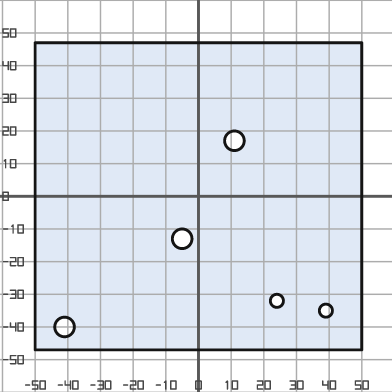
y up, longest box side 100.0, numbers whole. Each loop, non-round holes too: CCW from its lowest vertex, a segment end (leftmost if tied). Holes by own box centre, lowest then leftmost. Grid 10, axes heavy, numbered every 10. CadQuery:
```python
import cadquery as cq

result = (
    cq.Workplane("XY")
    .moveTo(-50.0, -47.0)
    .lineTo(50.0, -47.0)
    .lineTo(50.0, 47.0)
    .lineTo(-50.0, 47.0)
    .close()
    .moveTo(-41.0, -40.0)
    .circle(3.0)
    .moveTo(39.0, -35.0)
    .circle(2.0)
    .moveTo(24.0, -32.0)
    .circle(2.0)
    .moveTo(-5.0, -13.0)
    .circle(3.0)
    .moveTo(11.0, 17.0)
    .circle(3.0)
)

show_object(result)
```